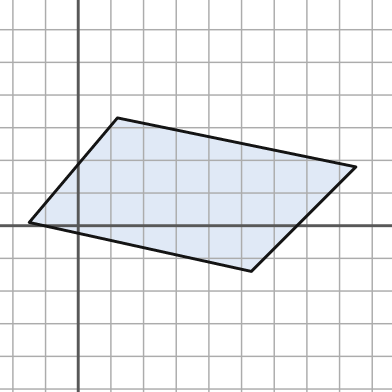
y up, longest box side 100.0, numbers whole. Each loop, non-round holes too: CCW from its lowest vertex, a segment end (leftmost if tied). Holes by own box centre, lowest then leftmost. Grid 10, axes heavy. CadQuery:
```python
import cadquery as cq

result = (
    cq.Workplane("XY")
    .moveTo(53.0, -14.0)
    .lineTo(85.0, 18.0)
    .lineTo(12.0, 33.0)
    .lineTo(-15.0, 1.0)
    .close()
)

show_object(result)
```